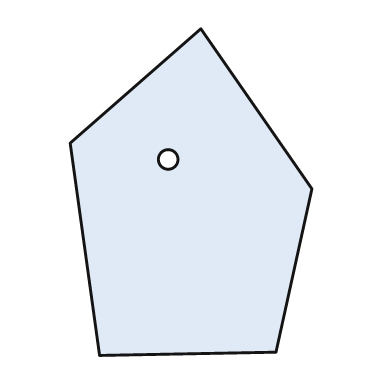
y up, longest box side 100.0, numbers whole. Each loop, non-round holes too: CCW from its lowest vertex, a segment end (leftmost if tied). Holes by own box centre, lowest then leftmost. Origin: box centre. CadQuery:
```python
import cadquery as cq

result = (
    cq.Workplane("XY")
    .moveTo(-28.0, -50.0)
    .lineTo(26.0, -49.0)
    .lineTo(37.0, 1.0)
    .lineTo(3.0, 50.0)
    .lineTo(-37.0, 15.0)
    .close()
    .moveTo(-7.0, 10.0)
    .circle(3.0)
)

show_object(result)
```